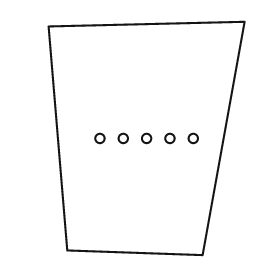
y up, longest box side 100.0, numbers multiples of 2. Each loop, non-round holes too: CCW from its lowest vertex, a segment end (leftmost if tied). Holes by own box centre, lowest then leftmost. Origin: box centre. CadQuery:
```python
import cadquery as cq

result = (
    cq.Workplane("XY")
    .moveTo(24.0, -50.0)
    .lineTo(42.0, 50.0)
    .lineTo(-42.0, 48.0)
    .lineTo(-34.0, -48.0)
    .close()
    .moveTo(-20.0, 0.0)
    .circle(2.0)
    .moveTo(-10.0, 0.0)
    .circle(2.0)
    .moveTo(0.0, 0.0)
    .circle(2.0)
    .moveTo(10.0, 0.0)
    .circle(2.0)
    .moveTo(20.0, 0.0)
    .circle(2.0)
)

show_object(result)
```